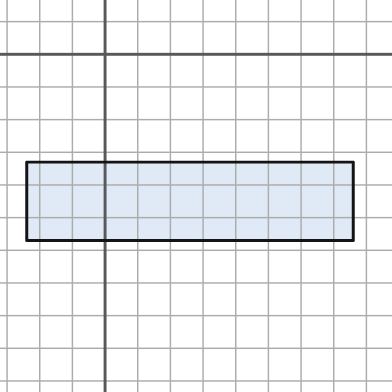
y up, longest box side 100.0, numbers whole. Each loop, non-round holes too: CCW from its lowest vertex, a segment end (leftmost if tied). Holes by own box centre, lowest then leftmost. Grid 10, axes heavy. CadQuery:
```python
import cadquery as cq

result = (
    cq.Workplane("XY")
    .moveTo(-24.0, -57.0)
    .lineTo(76.0, -57.0)
    .lineTo(76.0, -33.0)
    .lineTo(-24.0, -33.0)
    .close()
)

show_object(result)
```